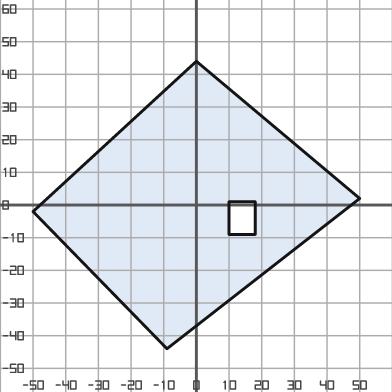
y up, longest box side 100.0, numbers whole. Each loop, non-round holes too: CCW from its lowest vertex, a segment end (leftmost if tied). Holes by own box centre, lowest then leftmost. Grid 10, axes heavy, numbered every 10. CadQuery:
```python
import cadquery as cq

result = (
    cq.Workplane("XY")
    .moveTo(-9.0, -44.0)
    .lineTo(50.0, 2.0)
    .lineTo(0.0, 44.0)
    .lineTo(-50.0, -2.0)
    .close()
    .moveTo(10.0, -9.0)
    .lineTo(18.0, -9.0)
    .lineTo(18.0, 1.0)
    .lineTo(10.0, 1.0)
    .close()
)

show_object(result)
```